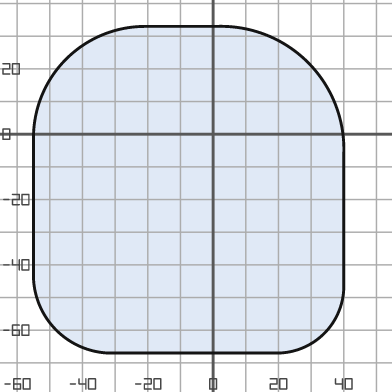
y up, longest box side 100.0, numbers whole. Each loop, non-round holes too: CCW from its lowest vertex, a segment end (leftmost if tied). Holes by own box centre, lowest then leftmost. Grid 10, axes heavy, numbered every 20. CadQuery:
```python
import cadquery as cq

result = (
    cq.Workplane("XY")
    .moveTo(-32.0, -67.0)
    .lineTo(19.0, -67.0)
    .threePointArc((34.0, -61.0), (40.0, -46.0))
    .lineTo(40.0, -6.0)
    .threePointArc((29.0, 22.0), (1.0, 33.0))
    .lineTo(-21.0, 33.0)
    .threePointArc((-45.0, 23.0), (-55.0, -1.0))
    .lineTo(-55.0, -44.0)
    .threePointArc((-48.0, -60.0), (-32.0, -67.0))
    .close()
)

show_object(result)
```